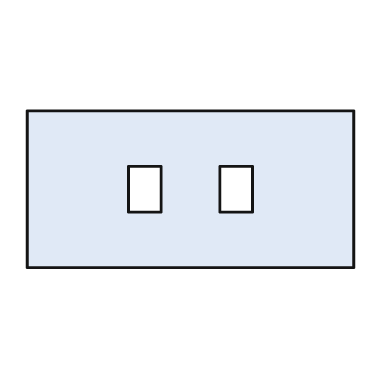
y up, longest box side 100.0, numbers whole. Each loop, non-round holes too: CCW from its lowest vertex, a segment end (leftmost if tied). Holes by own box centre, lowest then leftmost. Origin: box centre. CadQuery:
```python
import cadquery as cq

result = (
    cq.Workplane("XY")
    .moveTo(-50.0, -24.0)
    .lineTo(50.0, -24.0)
    .lineTo(50.0, 24.0)
    .lineTo(-50.0, 24.0)
    .close()
    .moveTo(-19.0, -7.0)
    .lineTo(-9.0, -7.0)
    .lineTo(-9.0, 7.0)
    .lineTo(-19.0, 7.0)
    .close()
    .moveTo(9.0, -7.0)
    .lineTo(19.0, -7.0)
    .lineTo(19.0, 7.0)
    .lineTo(9.0, 7.0)
    .close()
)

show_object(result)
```